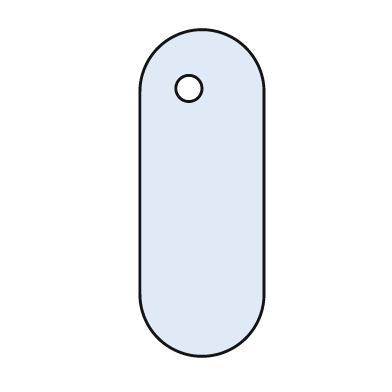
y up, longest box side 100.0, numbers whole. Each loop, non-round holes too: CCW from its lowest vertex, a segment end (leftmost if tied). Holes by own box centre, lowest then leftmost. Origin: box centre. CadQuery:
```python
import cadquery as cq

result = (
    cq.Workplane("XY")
    .moveTo(-19.0, -31.0)
    .threePointArc((0.0, -50.0), (19.0, -31.0))
    .lineTo(19.0, 31.0)
    .threePointArc((0.0, 50.0), (-19.0, 31.0))
    .close()
    .moveTo(-4.0, 32.0)
    .circle(4.0)
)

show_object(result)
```